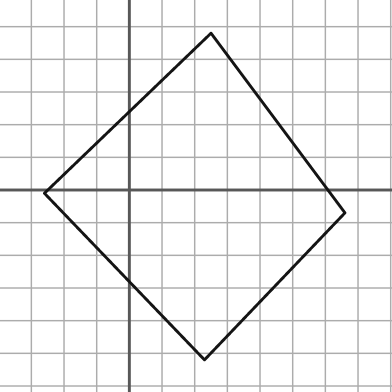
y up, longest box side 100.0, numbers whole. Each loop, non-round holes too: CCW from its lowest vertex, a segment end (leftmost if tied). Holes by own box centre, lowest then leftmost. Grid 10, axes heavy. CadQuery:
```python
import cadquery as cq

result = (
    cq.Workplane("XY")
    .moveTo(23.0, -52.0)
    .lineTo(66.0, -7.0)
    .lineTo(25.0, 48.0)
    .lineTo(-26.0, -1.0)
    .close()
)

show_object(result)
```